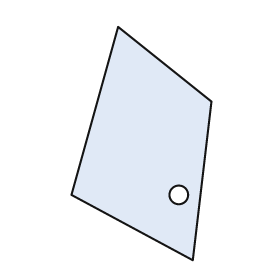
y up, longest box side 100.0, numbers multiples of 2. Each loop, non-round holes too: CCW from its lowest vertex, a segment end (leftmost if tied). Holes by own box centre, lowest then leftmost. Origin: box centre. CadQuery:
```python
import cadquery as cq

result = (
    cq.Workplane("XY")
    .moveTo(22.0, -50.0)
    .lineTo(30.0, 18.0)
    .lineTo(-10.0, 50.0)
    .lineTo(-30.0, -22.0)
    .close()
    .moveTo(16.0, -22.0)
    .circle(4.0)
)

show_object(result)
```